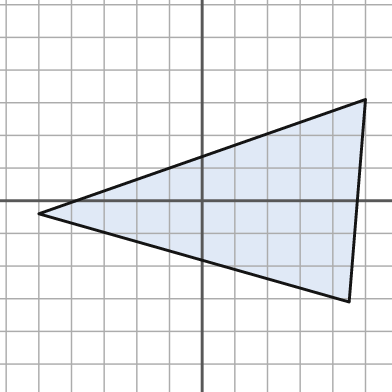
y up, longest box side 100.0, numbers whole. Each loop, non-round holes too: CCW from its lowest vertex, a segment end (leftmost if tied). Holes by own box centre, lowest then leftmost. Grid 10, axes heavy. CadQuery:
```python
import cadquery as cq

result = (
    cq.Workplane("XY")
    .moveTo(45.0, -31.0)
    .lineTo(50.0, 31.0)
    .lineTo(-50.0, -4.0)
    .close()
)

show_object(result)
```